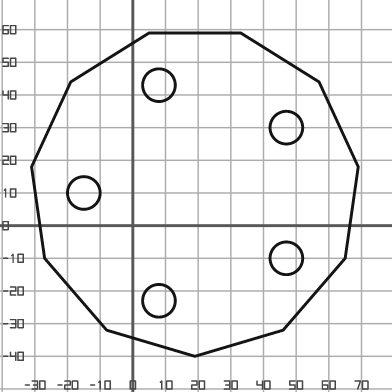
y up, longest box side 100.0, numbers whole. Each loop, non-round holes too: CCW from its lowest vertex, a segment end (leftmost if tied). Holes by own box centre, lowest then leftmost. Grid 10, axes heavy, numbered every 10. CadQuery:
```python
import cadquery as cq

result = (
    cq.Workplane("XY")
    .moveTo(19.0, -40.0)
    .lineTo(46.0, -32.0)
    .lineTo(65.0, -10.0)
    .lineTo(69.0, 18.0)
    .lineTo(57.0, 44.0)
    .lineTo(33.0, 59.0)
    .lineTo(5.0, 59.0)
    .lineTo(-19.0, 44.0)
    .lineTo(-31.0, 18.0)
    .lineTo(-27.0, -10.0)
    .lineTo(-8.0, -32.0)
    .close()
    .moveTo(8.0, -23.0)
    .circle(5.0)
    .moveTo(47.0, -10.0)
    .circle(5.0)
    .moveTo(-15.0, 10.0)
    .circle(5.0)
    .moveTo(47.0, 30.0)
    .circle(5.0)
    .moveTo(8.0, 43.0)
    .circle(5.0)
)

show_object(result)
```